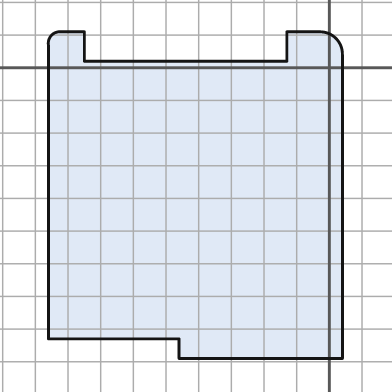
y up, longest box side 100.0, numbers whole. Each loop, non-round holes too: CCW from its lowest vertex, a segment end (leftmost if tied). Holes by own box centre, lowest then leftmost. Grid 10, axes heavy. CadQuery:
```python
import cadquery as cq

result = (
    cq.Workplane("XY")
    .moveTo(-46.0, -89.0)
    .lineTo(4.0, -89.0)
    .lineTo(4.0, 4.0)
    .threePointArc((2.0, 9.0), (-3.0, 11.0))
    .lineTo(-13.0, 11.0)
    .lineTo(-13.0, 2.0)
    .lineTo(-75.0, 2.0)
    .lineTo(-75.0, 11.0)
    .lineTo(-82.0, 11.0)
    .threePointArc((-85.0, 10.0), (-86.0, 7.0))
    .lineTo(-86.0, -83.0)
    .lineTo(-46.0, -83.0)
    .close()
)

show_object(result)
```